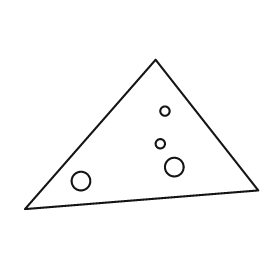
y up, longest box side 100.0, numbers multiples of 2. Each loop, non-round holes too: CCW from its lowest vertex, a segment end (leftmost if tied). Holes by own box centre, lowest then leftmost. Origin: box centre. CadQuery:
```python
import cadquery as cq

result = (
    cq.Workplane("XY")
    .moveTo(-50.0, -32.0)
    .lineTo(50.0, -24.0)
    .lineTo(6.0, 32.0)
    .close()
    .moveTo(-26.0, -20.0)
    .circle(4.0)
    .moveTo(14.0, -14.0)
    .circle(4.0)
    .moveTo(8.0, -4.0)
    .circle(2.0)
    .moveTo(10.0, 10.0)
    .circle(2.0)
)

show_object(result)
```